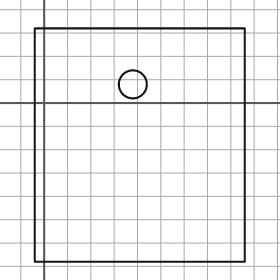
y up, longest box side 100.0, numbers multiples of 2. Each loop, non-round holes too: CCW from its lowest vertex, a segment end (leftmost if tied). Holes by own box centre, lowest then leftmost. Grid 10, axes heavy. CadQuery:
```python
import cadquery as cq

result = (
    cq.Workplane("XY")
    .moveTo(-4.0, -68.0)
    .lineTo(86.0, -68.0)
    .lineTo(86.0, 32.0)
    .lineTo(-4.0, 32.0)
    .close()
    .moveTo(38.0, 8.0)
    .circle(6.0)
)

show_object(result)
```